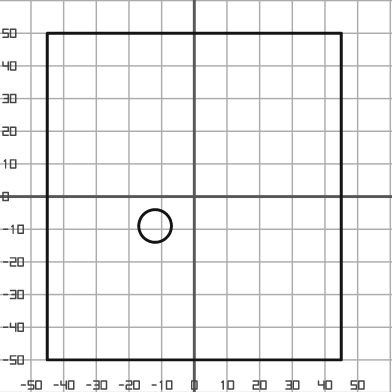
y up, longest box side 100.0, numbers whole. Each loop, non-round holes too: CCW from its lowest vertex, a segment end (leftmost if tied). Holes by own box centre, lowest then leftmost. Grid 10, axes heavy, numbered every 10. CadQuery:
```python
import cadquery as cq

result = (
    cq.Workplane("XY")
    .moveTo(-45.0, -50.0)
    .lineTo(45.0, -50.0)
    .lineTo(45.0, 50.0)
    .lineTo(-45.0, 50.0)
    .close()
    .moveTo(-12.0, -9.0)
    .circle(5.0)
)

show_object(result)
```